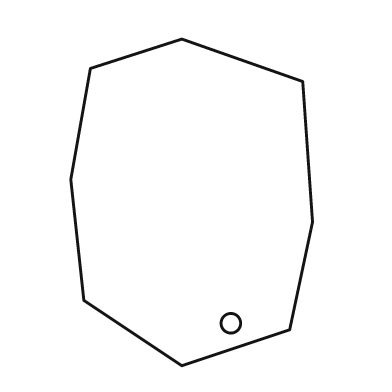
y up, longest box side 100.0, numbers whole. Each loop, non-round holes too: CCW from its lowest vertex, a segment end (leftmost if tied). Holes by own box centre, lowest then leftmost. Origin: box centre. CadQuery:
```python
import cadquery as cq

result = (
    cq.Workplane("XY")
    .moveTo(-3.0, -50.0)
    .lineTo(30.0, -39.0)
    .lineTo(37.0, -6.0)
    .lineTo(34.0, 37.0)
    .lineTo(-3.0, 50.0)
    .lineTo(-31.0, 41.0)
    .lineTo(-37.0, 7.0)
    .lineTo(-33.0, -30.0)
    .close()
    .moveTo(12.0, -37.0)
    .circle(3.0)
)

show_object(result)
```